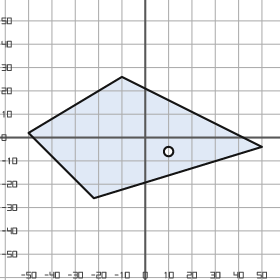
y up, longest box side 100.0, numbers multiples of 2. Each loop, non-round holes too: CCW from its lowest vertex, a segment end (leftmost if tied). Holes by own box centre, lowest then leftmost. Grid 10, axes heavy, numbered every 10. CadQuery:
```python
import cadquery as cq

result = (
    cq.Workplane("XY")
    .moveTo(-22.0, -26.0)
    .lineTo(50.0, -4.0)
    .lineTo(-10.0, 26.0)
    .lineTo(-50.0, 2.0)
    .close()
    .moveTo(10.0, -6.0)
    .circle(2.0)
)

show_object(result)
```